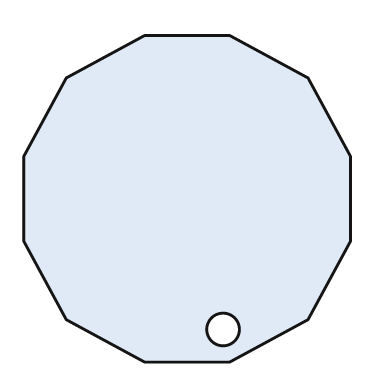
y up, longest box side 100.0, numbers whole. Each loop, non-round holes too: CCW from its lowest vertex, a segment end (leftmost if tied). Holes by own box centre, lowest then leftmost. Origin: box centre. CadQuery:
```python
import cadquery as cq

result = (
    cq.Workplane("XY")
    .moveTo(-13.0, -50.0)
    .lineTo(13.0, -50.0)
    .lineTo(37.0, -37.0)
    .lineTo(50.0, -13.0)
    .lineTo(50.0, 13.0)
    .lineTo(37.0, 37.0)
    .lineTo(13.0, 50.0)
    .lineTo(-13.0, 50.0)
    .lineTo(-37.0, 37.0)
    .lineTo(-50.0, 13.0)
    .lineTo(-50.0, -13.0)
    .lineTo(-37.0, -37.0)
    .close()
    .moveTo(11.0, -40.0)
    .circle(5.0)
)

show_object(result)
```